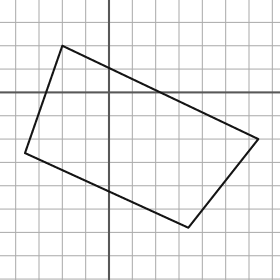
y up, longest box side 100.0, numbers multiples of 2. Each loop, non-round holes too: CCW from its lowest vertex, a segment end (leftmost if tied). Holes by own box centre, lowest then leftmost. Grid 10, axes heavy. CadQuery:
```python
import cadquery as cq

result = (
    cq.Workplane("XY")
    .moveTo(34.0, -58.0)
    .lineTo(64.0, -20.0)
    .lineTo(-20.0, 20.0)
    .lineTo(-36.0, -26.0)
    .close()
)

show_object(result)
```